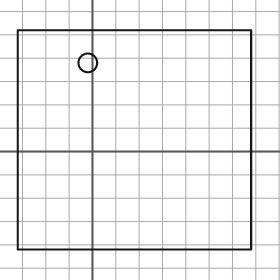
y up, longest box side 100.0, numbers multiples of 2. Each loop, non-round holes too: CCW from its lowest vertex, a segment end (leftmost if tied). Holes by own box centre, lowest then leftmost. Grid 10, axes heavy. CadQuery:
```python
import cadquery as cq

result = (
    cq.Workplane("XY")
    .moveTo(-32.0, -42.0)
    .lineTo(68.0, -42.0)
    .lineTo(68.0, 52.0)
    .lineTo(-32.0, 52.0)
    .close()
    .moveTo(-2.0, 38.0)
    .circle(4.0)
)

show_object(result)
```